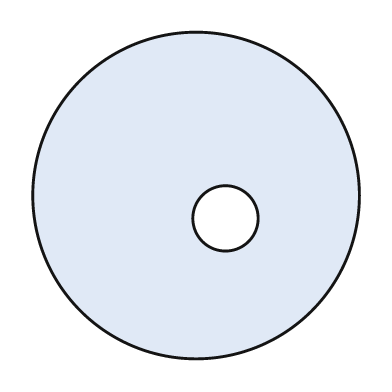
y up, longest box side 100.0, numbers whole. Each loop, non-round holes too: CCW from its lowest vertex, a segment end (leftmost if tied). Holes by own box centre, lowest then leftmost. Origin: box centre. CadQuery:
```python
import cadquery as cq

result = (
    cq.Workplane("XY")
    .moveTo(0.0, 0.0)
    .circle(50.0)
    .moveTo(9.0, -7.0)
    .circle(10.0)
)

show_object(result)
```